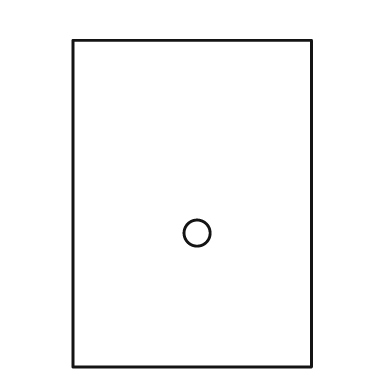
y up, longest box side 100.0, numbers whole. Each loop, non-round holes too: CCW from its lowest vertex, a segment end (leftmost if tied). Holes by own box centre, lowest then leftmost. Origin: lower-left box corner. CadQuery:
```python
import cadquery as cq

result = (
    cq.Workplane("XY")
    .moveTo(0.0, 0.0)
    .lineTo(73.0, 0.0)
    .lineTo(73.0, 100.0)
    .lineTo(0.0, 100.0)
    .close()
    .moveTo(38.0, 41.0)
    .circle(4.0)
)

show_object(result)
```